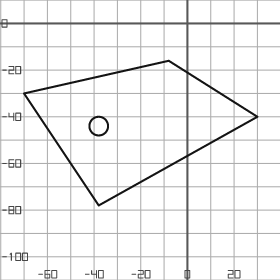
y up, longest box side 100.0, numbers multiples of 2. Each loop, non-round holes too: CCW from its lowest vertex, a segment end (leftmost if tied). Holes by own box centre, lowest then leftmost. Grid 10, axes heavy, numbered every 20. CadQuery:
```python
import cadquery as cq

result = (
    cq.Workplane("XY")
    .moveTo(-38.0, -78.0)
    .lineTo(30.0, -40.0)
    .lineTo(-8.0, -16.0)
    .lineTo(-70.0, -30.0)
    .close()
    .moveTo(-38.0, -44.0)
    .circle(4.0)
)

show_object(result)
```